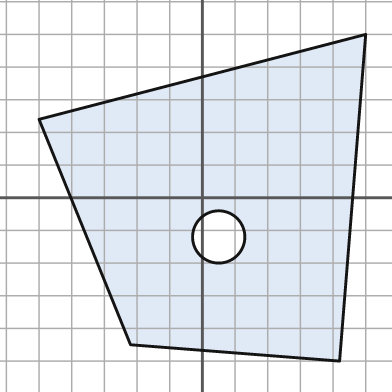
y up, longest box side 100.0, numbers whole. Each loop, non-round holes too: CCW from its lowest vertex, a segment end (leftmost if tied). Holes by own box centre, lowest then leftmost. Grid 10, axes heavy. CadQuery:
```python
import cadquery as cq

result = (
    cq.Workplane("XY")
    .moveTo(42.0, -50.0)
    .lineTo(50.0, 50.0)
    .lineTo(-50.0, 24.0)
    .lineTo(-22.0, -45.0)
    .close()
    .moveTo(5.0, -12.0)
    .circle(8.0)
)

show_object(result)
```